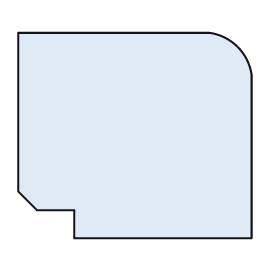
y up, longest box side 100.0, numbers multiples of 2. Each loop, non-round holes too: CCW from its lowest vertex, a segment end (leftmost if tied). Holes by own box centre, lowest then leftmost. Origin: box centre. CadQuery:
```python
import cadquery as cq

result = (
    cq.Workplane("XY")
    .moveTo(-26.0, -44.0)
    .lineTo(50.0, -44.0)
    .lineTo(50.0, 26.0)
    .threePointArc((44.0, 38.0), (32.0, 44.0))
    .lineTo(-50.0, 44.0)
    .lineTo(-50.0, -24.0)
    .lineTo(-42.0, -32.0)
    .lineTo(-26.0, -32.0)
    .close()
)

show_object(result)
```